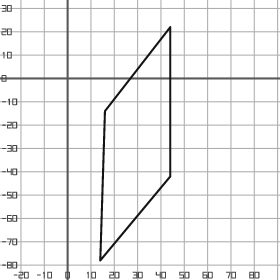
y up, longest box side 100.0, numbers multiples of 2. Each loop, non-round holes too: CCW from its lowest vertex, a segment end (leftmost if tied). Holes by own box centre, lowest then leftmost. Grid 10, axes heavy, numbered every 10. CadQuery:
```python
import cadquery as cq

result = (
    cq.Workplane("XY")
    .moveTo(14.0, -78.0)
    .lineTo(44.0, -42.0)
    .lineTo(44.0, 22.0)
    .lineTo(16.0, -14.0)
    .close()
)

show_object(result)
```